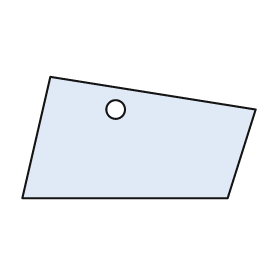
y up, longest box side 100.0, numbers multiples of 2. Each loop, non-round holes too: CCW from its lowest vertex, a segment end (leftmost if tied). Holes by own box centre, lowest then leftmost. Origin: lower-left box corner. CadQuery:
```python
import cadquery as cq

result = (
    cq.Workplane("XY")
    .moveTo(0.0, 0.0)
    .lineTo(88.0, 0.0)
    .lineTo(100.0, 38.0)
    .lineTo(12.0, 52.0)
    .close()
    .moveTo(40.0, 38.0)
    .circle(4.0)
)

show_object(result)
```